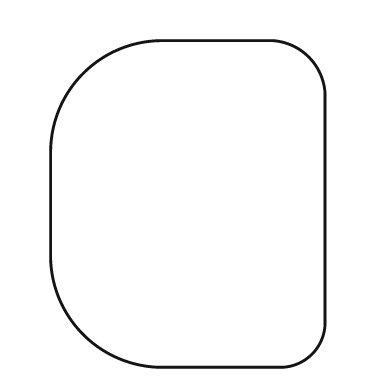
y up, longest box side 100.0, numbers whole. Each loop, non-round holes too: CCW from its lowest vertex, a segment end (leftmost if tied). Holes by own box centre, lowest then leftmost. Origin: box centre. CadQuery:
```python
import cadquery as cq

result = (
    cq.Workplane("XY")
    .moveTo(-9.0, -50.0)
    .lineTo(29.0, -50.0)
    .threePointArc((38.0, -46.0), (42.0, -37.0))
    .lineTo(42.0, 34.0)
    .threePointArc((37.0, 45.0), (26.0, 50.0))
    .lineTo(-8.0, 50.0)
    .threePointArc((-32.0, 40.0), (-42.0, 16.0))
    .lineTo(-42.0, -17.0)
    .threePointArc((-32.0, -40.0), (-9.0, -50.0))
    .close()
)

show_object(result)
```